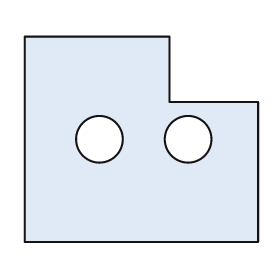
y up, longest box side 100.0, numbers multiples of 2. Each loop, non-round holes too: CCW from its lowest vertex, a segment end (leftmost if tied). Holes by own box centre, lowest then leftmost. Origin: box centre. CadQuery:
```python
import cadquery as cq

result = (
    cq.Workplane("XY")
    .moveTo(-50.0, -44.0)
    .lineTo(50.0, -44.0)
    .lineTo(50.0, 16.0)
    .lineTo(12.0, 16.0)
    .lineTo(12.0, 44.0)
    .lineTo(-50.0, 44.0)
    .close()
    .moveTo(-18.0, 0.0)
    .circle(10.0)
    .moveTo(20.0, 0.0)
    .circle(10.0)
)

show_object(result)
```